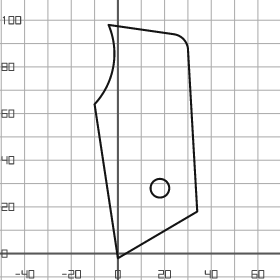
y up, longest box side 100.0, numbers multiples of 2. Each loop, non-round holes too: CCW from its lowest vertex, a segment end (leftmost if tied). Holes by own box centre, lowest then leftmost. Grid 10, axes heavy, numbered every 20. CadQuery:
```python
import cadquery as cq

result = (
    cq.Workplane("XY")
    .moveTo(0.0, -2.0)
    .lineTo(34.0, 18.0)
    .lineTo(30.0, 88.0)
    .threePointArc((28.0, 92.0), (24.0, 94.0))
    .lineTo(-4.0, 98.0)
    .threePointArc((-2.0, 80.0), (-10.0, 64.0))
    .close()
    .moveTo(18.0, 28.0)
    .circle(4.0)
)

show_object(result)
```